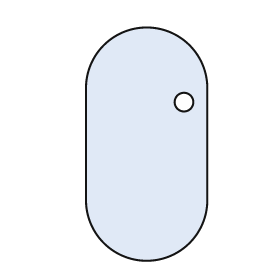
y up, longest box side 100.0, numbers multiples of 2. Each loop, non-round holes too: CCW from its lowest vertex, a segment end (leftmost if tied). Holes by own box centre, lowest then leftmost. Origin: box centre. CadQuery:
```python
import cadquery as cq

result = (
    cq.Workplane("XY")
    .moveTo(-26.0, -24.0)
    .threePointArc((0.0, -50.0), (26.0, -24.0))
    .lineTo(26.0, 24.0)
    .threePointArc((0.0, 50.0), (-26.0, 24.0))
    .close()
    .moveTo(16.0, 18.0)
    .circle(4.0)
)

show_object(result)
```